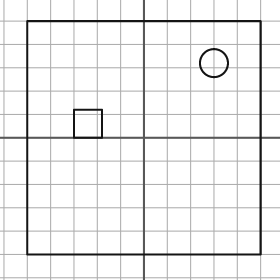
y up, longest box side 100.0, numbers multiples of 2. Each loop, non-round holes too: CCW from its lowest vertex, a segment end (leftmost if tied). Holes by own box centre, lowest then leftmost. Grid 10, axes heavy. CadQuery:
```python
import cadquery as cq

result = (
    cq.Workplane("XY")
    .moveTo(-50.0, -50.0)
    .lineTo(50.0, -50.0)
    .lineTo(50.0, 50.0)
    .lineTo(-50.0, 50.0)
    .close()
    .moveTo(-30.0, 0.0)
    .lineTo(-18.0, 0.0)
    .lineTo(-18.0, 12.0)
    .lineTo(-30.0, 12.0)
    .close()
    .moveTo(30.0, 32.0)
    .circle(6.0)
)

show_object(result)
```